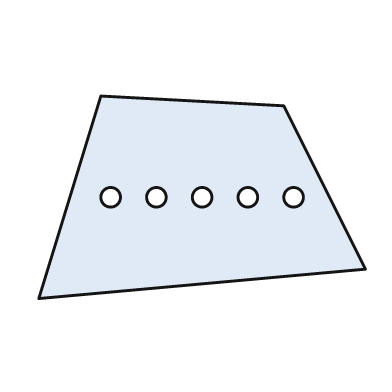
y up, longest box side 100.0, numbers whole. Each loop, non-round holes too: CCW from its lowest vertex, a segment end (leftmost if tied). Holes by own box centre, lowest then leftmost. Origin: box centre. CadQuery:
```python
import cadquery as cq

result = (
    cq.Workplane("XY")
    .moveTo(-50.0, -31.0)
    .lineTo(50.0, -22.0)
    .lineTo(25.0, 28.0)
    .lineTo(-31.0, 31.0)
    .close()
    .moveTo(-28.0, 0.0)
    .circle(3.0)
    .moveTo(-14.0, 0.0)
    .circle(3.0)
    .moveTo(0.0, 0.0)
    .circle(3.0)
    .moveTo(14.0, 0.0)
    .circle(3.0)
    .moveTo(28.0, 0.0)
    .circle(3.0)
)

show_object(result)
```